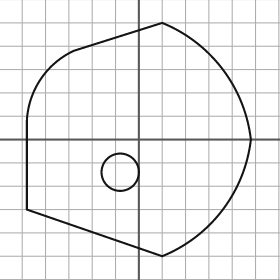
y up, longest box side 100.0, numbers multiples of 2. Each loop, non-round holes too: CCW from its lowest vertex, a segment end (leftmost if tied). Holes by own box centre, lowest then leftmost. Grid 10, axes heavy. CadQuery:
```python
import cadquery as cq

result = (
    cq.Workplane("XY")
    .moveTo(10.0, -50.0)
    .threePointArc((36.0, -30.0), (48.0, 0.0))
    .threePointArc((36.0, 30.0), (10.0, 50.0))
    .lineTo(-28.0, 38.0)
    .threePointArc((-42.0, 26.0), (-48.0, 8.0))
    .lineTo(-48.0, -30.0)
    .close()
    .moveTo(-8.0, -14.0)
    .circle(8.0)
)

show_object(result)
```